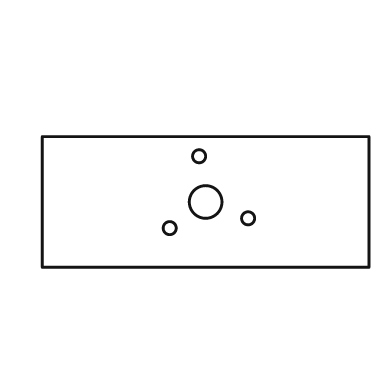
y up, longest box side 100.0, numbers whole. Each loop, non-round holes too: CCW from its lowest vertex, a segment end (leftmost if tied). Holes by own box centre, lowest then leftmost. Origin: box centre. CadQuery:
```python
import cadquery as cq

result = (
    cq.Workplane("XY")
    .moveTo(-50.0, -20.0)
    .lineTo(50.0, -20.0)
    .lineTo(50.0, 20.0)
    .lineTo(-50.0, 20.0)
    .close()
    .moveTo(-11.0, -8.0)
    .circle(2.0)
    .moveTo(13.0, -5.0)
    .circle(2.0)
    .moveTo(0.0, 0.0)
    .circle(5.0)
    .moveTo(-2.0, 14.0)
    .circle(2.0)
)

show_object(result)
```